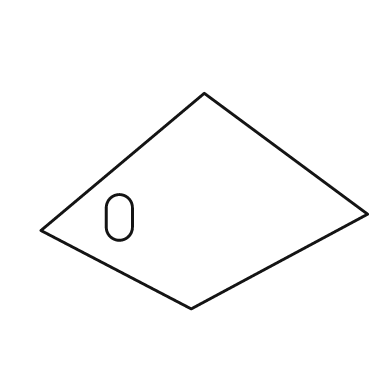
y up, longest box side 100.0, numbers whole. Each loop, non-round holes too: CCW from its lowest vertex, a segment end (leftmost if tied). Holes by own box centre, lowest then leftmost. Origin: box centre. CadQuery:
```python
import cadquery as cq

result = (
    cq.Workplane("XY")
    .moveTo(-4.0, -33.0)
    .lineTo(50.0, -4.0)
    .lineTo(0.0, 33.0)
    .lineTo(-50.0, -9.0)
    .close()
    .moveTo(-30.0, -8.0)
    .threePointArc((-26.0, -12.0), (-22.0, -8.0))
    .lineTo(-22.0, -2.0)
    .threePointArc((-26.0, 2.0), (-30.0, -2.0))
    .close()
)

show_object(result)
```